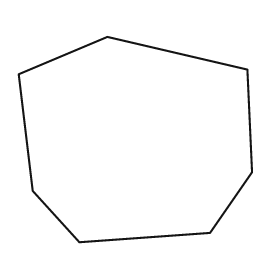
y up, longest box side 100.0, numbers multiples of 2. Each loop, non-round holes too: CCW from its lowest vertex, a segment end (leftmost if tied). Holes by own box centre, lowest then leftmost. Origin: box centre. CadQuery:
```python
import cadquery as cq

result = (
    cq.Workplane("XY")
    .moveTo(-24.0, -44.0)
    .lineTo(32.0, -40.0)
    .lineTo(50.0, -14.0)
    .lineTo(48.0, 30.0)
    .lineTo(-12.0, 44.0)
    .lineTo(-50.0, 28.0)
    .lineTo(-44.0, -22.0)
    .close()
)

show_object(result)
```